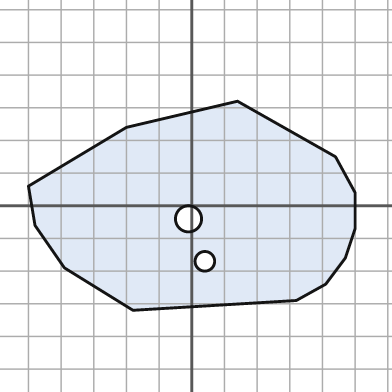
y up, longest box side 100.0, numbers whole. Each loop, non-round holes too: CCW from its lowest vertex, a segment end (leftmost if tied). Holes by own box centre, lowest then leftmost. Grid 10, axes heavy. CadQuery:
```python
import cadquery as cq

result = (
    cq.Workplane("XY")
    .moveTo(-18.0, -32.0)
    .lineTo(32.0, -29.0)
    .lineTo(41.0, -24.0)
    .lineTo(47.0, -16.0)
    .lineTo(50.0, -7.0)
    .lineTo(50.0, 4.0)
    .lineTo(44.0, 15.0)
    .lineTo(14.0, 32.0)
    .lineTo(-20.0, 24.0)
    .lineTo(-50.0, 6.0)
    .lineTo(-48.0, -6.0)
    .lineTo(-39.0, -19.0)
    .close()
    .moveTo(4.0, -17.0)
    .circle(3.0)
    .moveTo(-1.0, -4.0)
    .circle(4.0)
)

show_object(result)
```